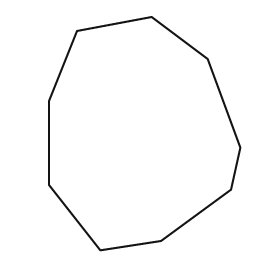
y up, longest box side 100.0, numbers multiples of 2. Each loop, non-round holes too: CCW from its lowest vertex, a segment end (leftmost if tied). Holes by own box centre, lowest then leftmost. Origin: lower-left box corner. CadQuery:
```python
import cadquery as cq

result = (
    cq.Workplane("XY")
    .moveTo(22.0, 0.0)
    .lineTo(48.0, 4.0)
    .lineTo(78.0, 26.0)
    .lineTo(82.0, 44.0)
    .lineTo(68.0, 82.0)
    .lineTo(44.0, 100.0)
    .lineTo(12.0, 94.0)
    .lineTo(0.0, 64.0)
    .lineTo(0.0, 28.0)
    .close()
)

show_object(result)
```